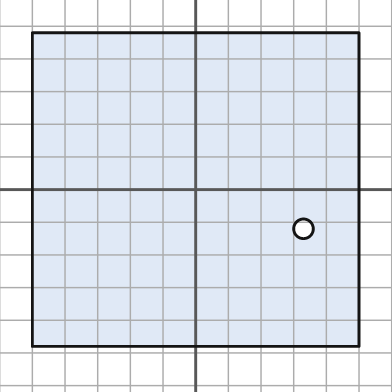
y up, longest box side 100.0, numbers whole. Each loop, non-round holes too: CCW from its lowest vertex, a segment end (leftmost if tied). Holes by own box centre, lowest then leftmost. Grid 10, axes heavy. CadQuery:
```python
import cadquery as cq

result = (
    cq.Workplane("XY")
    .moveTo(-50.0, -48.0)
    .lineTo(50.0, -48.0)
    .lineTo(50.0, 48.0)
    .lineTo(-50.0, 48.0)
    .close()
    .moveTo(33.0, -12.0)
    .circle(3.0)
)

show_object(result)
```